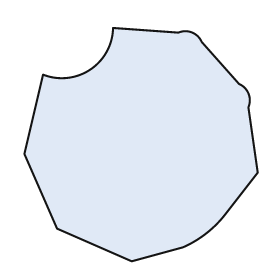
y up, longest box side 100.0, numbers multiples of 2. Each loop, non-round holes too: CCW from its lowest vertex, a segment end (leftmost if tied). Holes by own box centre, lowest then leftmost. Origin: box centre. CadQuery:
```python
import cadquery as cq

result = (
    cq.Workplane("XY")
    .moveTo(-4.0, -50.0)
    .lineTo(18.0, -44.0)
    .threePointArc((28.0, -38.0), (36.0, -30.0))
    .lineTo(50.0, -12.0)
    .lineTo(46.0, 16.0)
    .threePointArc((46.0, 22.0), (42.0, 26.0))
    .lineTo(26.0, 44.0)
    .threePointArc((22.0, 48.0), (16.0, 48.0))
    .lineTo(-12.0, 50.0)
    .threePointArc((-22.0, 32.0), (-42.0, 30.0))
    .lineTo(-50.0, -4.0)
    .lineTo(-36.0, -36.0)
    .close()
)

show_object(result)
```